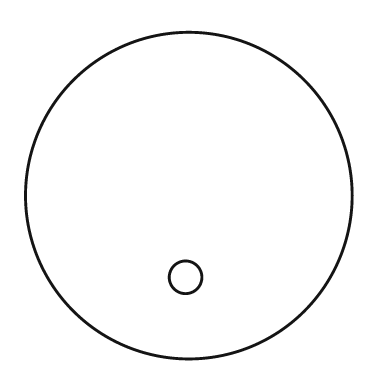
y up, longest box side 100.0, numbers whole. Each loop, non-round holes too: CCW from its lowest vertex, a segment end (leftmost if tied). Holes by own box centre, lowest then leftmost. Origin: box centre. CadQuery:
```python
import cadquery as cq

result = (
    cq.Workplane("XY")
    .moveTo(0.0, 0.0)
    .circle(50.0)
    .moveTo(-1.0, -25.0)
    .circle(5.0)
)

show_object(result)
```